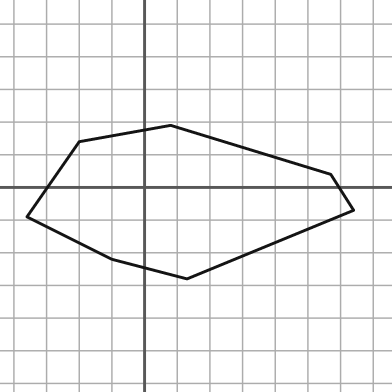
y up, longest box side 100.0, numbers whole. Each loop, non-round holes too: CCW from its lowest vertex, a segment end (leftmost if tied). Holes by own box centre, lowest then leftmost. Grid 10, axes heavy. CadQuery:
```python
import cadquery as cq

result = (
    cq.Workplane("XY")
    .moveTo(13.0, -28.0)
    .lineTo(64.0, -7.0)
    .lineTo(57.0, 4.0)
    .lineTo(8.0, 19.0)
    .lineTo(-20.0, 14.0)
    .lineTo(-36.0, -9.0)
    .lineTo(-10.0, -22.0)
    .close()
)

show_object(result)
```